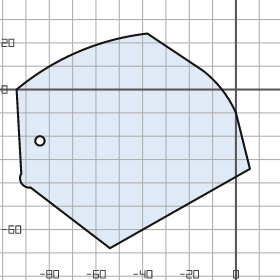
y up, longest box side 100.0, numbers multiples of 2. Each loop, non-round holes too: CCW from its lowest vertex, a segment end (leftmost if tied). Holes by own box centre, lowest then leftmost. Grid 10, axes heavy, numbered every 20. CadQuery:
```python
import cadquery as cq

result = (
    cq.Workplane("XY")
    .moveTo(-54.0, -68.0)
    .lineTo(6.0, -34.0)
    .lineTo(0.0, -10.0)
    .threePointArc((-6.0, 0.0), (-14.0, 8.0))
    .lineTo(-38.0, 24.0)
    .threePointArc((-68.0, 16.0), (-94.0, 0.0))
    .lineTo(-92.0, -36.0)
    .threePointArc((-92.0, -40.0), (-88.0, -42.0))
    .close()
    .moveTo(-84.0, -22.0)
    .circle(2.0)
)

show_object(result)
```